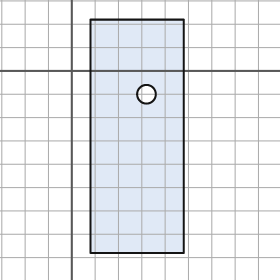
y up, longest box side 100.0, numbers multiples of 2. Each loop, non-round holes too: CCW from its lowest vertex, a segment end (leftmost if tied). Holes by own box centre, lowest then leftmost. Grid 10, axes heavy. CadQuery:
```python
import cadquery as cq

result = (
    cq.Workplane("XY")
    .moveTo(8.0, -78.0)
    .lineTo(48.0, -78.0)
    .lineTo(48.0, 22.0)
    .lineTo(8.0, 22.0)
    .close()
    .moveTo(32.0, -10.0)
    .circle(4.0)
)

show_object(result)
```